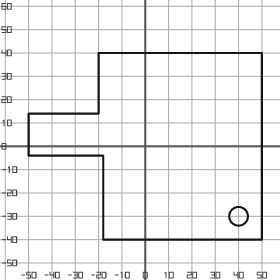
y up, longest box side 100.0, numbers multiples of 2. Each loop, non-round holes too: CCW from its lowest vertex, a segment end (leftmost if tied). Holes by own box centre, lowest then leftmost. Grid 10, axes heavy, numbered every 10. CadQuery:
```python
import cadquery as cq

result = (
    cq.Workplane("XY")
    .moveTo(-18.0, -40.0)
    .lineTo(50.0, -40.0)
    .lineTo(50.0, 40.0)
    .lineTo(-20.0, 40.0)
    .lineTo(-20.0, 14.0)
    .lineTo(-50.0, 14.0)
    .lineTo(-50.0, -4.0)
    .lineTo(-18.0, -4.0)
    .close()
    .moveTo(40.0, -30.0)
    .circle(4.0)
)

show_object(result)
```